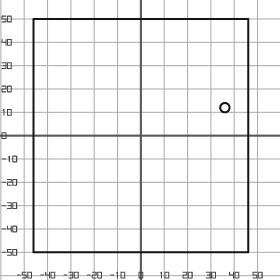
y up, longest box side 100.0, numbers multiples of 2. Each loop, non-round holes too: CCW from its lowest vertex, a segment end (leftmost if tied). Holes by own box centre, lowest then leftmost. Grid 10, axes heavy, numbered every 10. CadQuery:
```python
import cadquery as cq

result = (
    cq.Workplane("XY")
    .moveTo(-46.0, -50.0)
    .lineTo(46.0, -50.0)
    .lineTo(46.0, 50.0)
    .lineTo(-46.0, 50.0)
    .close()
    .moveTo(36.0, 12.0)
    .circle(2.0)
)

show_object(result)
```